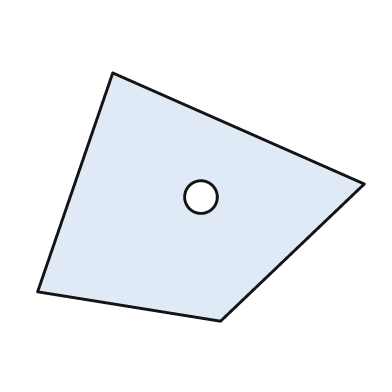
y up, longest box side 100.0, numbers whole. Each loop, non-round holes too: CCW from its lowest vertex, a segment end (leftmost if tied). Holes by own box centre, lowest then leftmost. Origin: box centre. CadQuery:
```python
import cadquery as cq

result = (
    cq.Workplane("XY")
    .moveTo(6.0, -38.0)
    .lineTo(50.0, 4.0)
    .lineTo(-27.0, 38.0)
    .lineTo(-50.0, -29.0)
    .close()
    .moveTo(0.0, 0.0)
    .circle(5.0)
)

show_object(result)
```